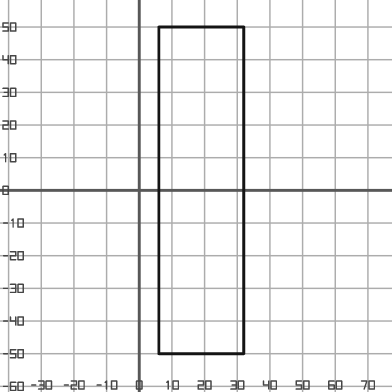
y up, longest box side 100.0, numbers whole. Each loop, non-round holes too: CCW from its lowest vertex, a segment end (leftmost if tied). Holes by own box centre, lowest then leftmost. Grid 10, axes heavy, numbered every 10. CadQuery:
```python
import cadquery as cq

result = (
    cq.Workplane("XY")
    .moveTo(6.0, -50.0)
    .lineTo(32.0, -50.0)
    .lineTo(32.0, 50.0)
    .lineTo(6.0, 50.0)
    .close()
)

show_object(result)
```